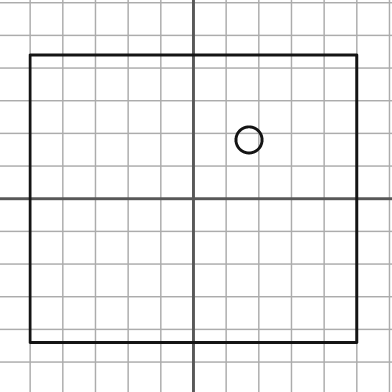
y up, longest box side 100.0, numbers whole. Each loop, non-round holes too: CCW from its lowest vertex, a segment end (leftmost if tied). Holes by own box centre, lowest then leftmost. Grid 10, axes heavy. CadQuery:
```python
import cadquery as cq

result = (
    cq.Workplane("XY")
    .moveTo(-50.0, -44.0)
    .lineTo(50.0, -44.0)
    .lineTo(50.0, 44.0)
    .lineTo(-50.0, 44.0)
    .close()
    .moveTo(17.0, 18.0)
    .circle(4.0)
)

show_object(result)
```